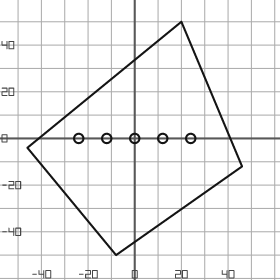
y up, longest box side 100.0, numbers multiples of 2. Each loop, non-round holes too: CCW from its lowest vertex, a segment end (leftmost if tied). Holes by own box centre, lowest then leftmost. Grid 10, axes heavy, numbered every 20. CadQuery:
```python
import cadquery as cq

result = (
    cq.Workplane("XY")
    .moveTo(-8.0, -50.0)
    .lineTo(46.0, -12.0)
    .lineTo(20.0, 50.0)
    .lineTo(-46.0, -4.0)
    .close()
    .moveTo(-24.0, 0.0)
    .circle(2.0)
    .moveTo(-12.0, 0.0)
    .circle(2.0)
    .moveTo(0.0, 0.0)
    .circle(2.0)
    .moveTo(12.0, 0.0)
    .circle(2.0)
    .moveTo(24.0, 0.0)
    .circle(2.0)
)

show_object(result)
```